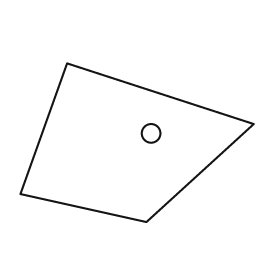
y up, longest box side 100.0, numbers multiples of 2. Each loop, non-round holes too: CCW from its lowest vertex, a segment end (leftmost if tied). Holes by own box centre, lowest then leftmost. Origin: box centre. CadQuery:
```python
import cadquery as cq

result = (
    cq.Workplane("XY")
    .moveTo(4.0, -34.0)
    .lineTo(50.0, 8.0)
    .lineTo(-30.0, 34.0)
    .lineTo(-50.0, -22.0)
    .close()
    .moveTo(6.0, 4.0)
    .circle(4.0)
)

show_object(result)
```